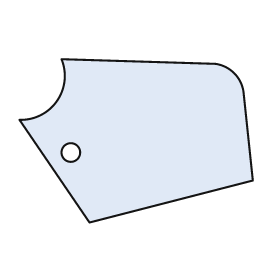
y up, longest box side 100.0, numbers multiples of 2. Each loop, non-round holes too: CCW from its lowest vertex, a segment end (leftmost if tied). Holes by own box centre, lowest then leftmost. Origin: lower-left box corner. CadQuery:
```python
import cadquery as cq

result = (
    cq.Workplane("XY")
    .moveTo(30.0, 0.0)
    .lineTo(100.0, 18.0)
    .lineTo(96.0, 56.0)
    .threePointArc((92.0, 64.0), (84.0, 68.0))
    .lineTo(18.0, 70.0)
    .threePointArc((16.0, 52.0), (0.0, 44.0))
    .close()
    .moveTo(22.0, 30.0)
    .circle(4.0)
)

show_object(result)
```